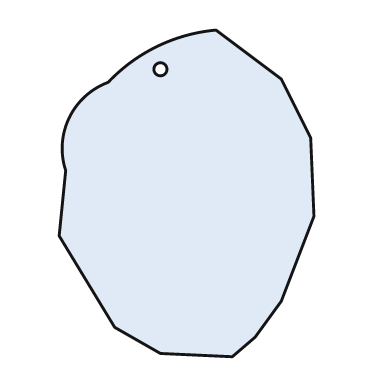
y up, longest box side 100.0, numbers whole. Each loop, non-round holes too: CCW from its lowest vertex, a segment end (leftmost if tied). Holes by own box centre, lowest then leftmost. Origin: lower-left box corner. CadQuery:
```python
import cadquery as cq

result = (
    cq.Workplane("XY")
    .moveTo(53.0, 0.0)
    .lineTo(60.0, 6.0)
    .lineTo(68.0, 17.0)
    .lineTo(78.0, 43.0)
    .lineTo(77.0, 67.0)
    .lineTo(68.0, 85.0)
    .lineTo(48.0, 100.0)
    .threePointArc((30.0, 95.0), (15.0, 84.0))
    .threePointArc((3.0, 73.0), (2.0, 57.0))
    .lineTo(0.0, 37.0)
    .lineTo(17.0, 9.0)
    .lineTo(31.0, 1.0)
    .close()
    .moveTo(31.0, 88.0)
    .circle(2.0)
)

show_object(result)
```